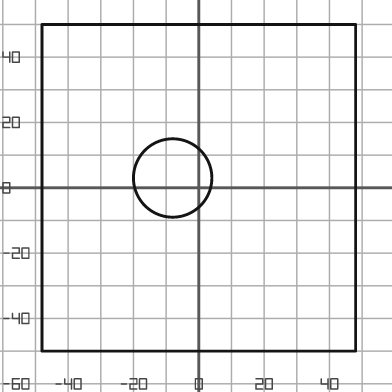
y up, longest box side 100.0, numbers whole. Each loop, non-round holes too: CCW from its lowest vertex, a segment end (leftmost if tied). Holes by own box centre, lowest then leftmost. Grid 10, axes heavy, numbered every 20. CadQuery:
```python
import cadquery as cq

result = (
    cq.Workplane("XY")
    .moveTo(-48.0, -50.0)
    .lineTo(48.0, -50.0)
    .lineTo(48.0, 50.0)
    .lineTo(-48.0, 50.0)
    .close()
    .moveTo(-8.0, 3.0)
    .circle(12.0)
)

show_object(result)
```